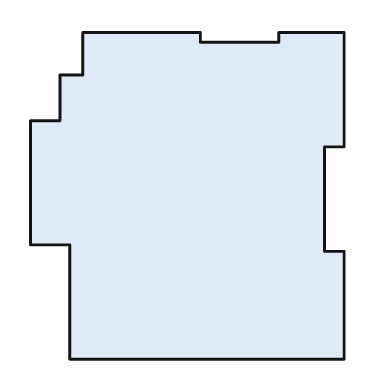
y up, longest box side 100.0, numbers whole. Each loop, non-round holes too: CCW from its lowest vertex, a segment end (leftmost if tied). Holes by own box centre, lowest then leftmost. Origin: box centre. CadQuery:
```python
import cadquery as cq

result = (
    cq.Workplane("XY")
    .moveTo(-36.0, -50.0)
    .lineTo(48.0, -50.0)
    .lineTo(48.0, -17.0)
    .lineTo(42.0, -17.0)
    .lineTo(42.0, 15.0)
    .lineTo(48.0, 15.0)
    .lineTo(48.0, 50.0)
    .lineTo(28.0, 50.0)
    .lineTo(28.0, 47.0)
    .lineTo(4.0, 47.0)
    .lineTo(4.0, 50.0)
    .lineTo(-32.0, 50.0)
    .lineTo(-32.0, 37.0)
    .lineTo(-39.0, 37.0)
    .lineTo(-39.0, 23.0)
    .lineTo(-48.0, 23.0)
    .lineTo(-48.0, -15.0)
    .lineTo(-36.0, -15.0)
    .close()
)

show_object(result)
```